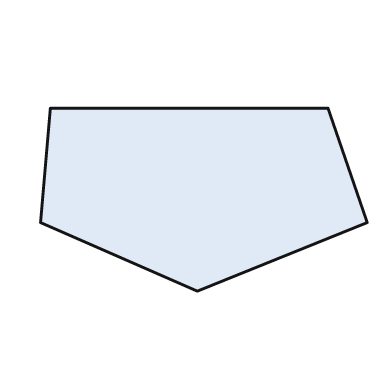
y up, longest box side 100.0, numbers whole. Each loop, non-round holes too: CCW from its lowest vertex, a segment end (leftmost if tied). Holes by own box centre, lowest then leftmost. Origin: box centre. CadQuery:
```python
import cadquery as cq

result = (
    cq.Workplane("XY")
    .moveTo(-2.0, -28.0)
    .lineTo(50.0, -7.0)
    .lineTo(38.0, 28.0)
    .lineTo(-47.0, 28.0)
    .lineTo(-50.0, -7.0)
    .close()
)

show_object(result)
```